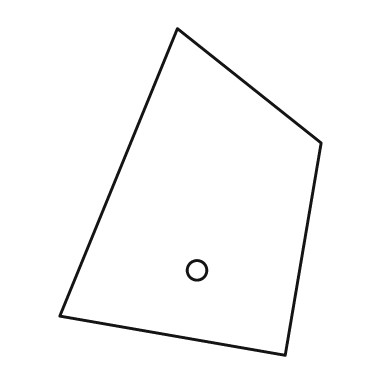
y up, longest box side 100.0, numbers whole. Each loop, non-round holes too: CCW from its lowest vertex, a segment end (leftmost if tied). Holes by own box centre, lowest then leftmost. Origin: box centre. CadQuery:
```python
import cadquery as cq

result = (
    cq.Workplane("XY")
    .moveTo(29.0, -50.0)
    .lineTo(40.0, 15.0)
    .lineTo(-4.0, 50.0)
    .lineTo(-40.0, -38.0)
    .close()
    .moveTo(2.0, -24.0)
    .circle(3.0)
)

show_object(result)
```